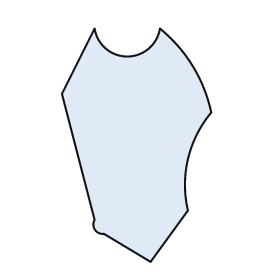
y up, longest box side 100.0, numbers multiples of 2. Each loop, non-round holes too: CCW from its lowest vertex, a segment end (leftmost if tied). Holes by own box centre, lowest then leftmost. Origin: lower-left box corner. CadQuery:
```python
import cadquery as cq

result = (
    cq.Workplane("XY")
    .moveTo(38.0, 0.0)
    .lineTo(54.0, 22.0)
    .threePointArc((54.0, 44.0), (64.0, 64.0))
    .threePointArc((56.0, 84.0), (42.0, 100.0))
    .threePointArc((28.0, 88.0), (14.0, 100.0))
    .lineTo(0.0, 72.0)
    .lineTo(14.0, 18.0)
    .threePointArc((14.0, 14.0), (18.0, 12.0))
    .close()
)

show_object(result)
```